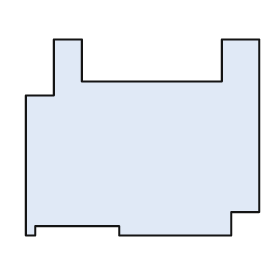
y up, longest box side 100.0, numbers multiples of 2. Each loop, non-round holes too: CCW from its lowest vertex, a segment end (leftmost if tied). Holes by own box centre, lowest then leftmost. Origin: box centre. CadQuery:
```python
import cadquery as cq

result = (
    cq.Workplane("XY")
    .moveTo(-50.0, -42.0)
    .lineTo(-46.0, -42.0)
    .lineTo(-46.0, -38.0)
    .lineTo(-10.0, -38.0)
    .lineTo(-10.0, -42.0)
    .lineTo(38.0, -42.0)
    .lineTo(38.0, -32.0)
    .lineTo(50.0, -32.0)
    .lineTo(50.0, 42.0)
    .lineTo(34.0, 42.0)
    .lineTo(34.0, 24.0)
    .lineTo(-26.0, 24.0)
    .lineTo(-26.0, 42.0)
    .lineTo(-38.0, 42.0)
    .lineTo(-38.0, 18.0)
    .lineTo(-50.0, 18.0)
    .close()
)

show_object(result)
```